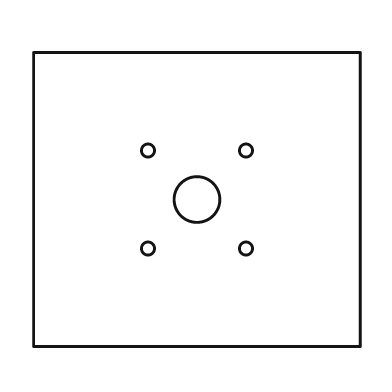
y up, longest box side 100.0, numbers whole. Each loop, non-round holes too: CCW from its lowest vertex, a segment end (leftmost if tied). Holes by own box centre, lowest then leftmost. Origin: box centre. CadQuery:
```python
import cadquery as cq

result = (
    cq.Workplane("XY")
    .moveTo(-50.0, -45.0)
    .lineTo(50.0, -45.0)
    .lineTo(50.0, 45.0)
    .lineTo(-50.0, 45.0)
    .close()
    .moveTo(-15.0, -15.0)
    .circle(2.0)
    .moveTo(15.0, -15.0)
    .circle(2.0)
    .moveTo(0.0, 0.0)
    .circle(7.0)
    .moveTo(-15.0, 15.0)
    .circle(2.0)
    .moveTo(15.0, 15.0)
    .circle(2.0)
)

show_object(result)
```